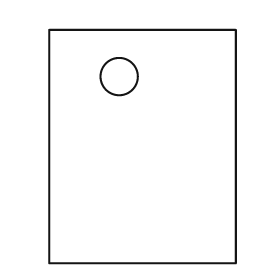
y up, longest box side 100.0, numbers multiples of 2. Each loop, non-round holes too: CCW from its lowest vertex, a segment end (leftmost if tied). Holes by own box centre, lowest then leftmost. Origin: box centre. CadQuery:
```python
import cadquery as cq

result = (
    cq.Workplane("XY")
    .moveTo(-40.0, -50.0)
    .lineTo(40.0, -50.0)
    .lineTo(40.0, 50.0)
    .lineTo(-40.0, 50.0)
    .close()
    .moveTo(-10.0, 30.0)
    .circle(8.0)
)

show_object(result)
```